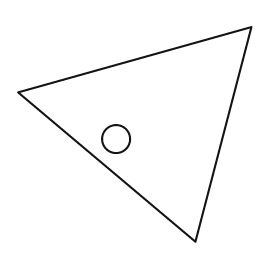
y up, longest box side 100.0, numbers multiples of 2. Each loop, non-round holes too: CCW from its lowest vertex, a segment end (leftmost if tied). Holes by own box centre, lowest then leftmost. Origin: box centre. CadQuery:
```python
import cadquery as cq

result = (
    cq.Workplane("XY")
    .moveTo(26.0, -46.0)
    .lineTo(50.0, 46.0)
    .lineTo(-50.0, 18.0)
    .close()
    .moveTo(-8.0, -2.0)
    .circle(6.0)
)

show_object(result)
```